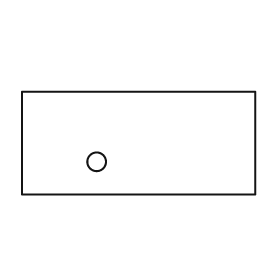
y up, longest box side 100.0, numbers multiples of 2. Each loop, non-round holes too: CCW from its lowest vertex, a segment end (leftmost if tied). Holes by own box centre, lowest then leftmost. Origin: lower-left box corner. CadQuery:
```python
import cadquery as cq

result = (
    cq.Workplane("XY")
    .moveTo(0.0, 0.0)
    .lineTo(100.0, 0.0)
    .lineTo(100.0, 44.0)
    .lineTo(0.0, 44.0)
    .close()
    .moveTo(32.0, 14.0)
    .circle(4.0)
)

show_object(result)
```